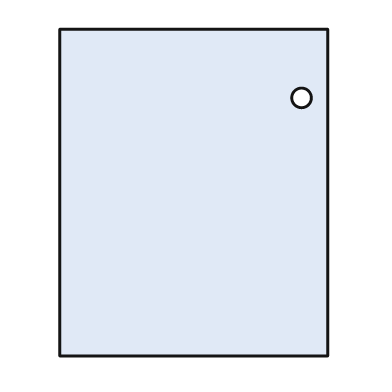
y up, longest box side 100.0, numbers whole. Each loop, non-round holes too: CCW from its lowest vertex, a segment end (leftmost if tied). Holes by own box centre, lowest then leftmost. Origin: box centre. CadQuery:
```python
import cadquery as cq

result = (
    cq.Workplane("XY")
    .moveTo(-41.0, -50.0)
    .lineTo(41.0, -50.0)
    .lineTo(41.0, 50.0)
    .lineTo(-41.0, 50.0)
    .close()
    .moveTo(33.0, 29.0)
    .circle(3.0)
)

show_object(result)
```